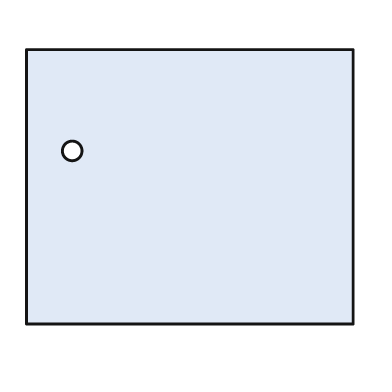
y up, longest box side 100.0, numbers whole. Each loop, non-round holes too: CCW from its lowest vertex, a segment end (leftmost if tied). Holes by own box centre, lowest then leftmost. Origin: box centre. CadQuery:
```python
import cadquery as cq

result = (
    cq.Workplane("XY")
    .moveTo(-50.0, -42.0)
    .lineTo(50.0, -42.0)
    .lineTo(50.0, 42.0)
    .lineTo(-50.0, 42.0)
    .close()
    .moveTo(-36.0, 11.0)
    .circle(3.0)
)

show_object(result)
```